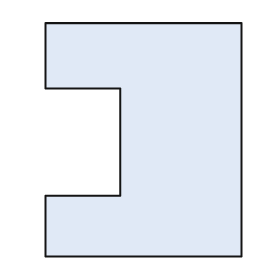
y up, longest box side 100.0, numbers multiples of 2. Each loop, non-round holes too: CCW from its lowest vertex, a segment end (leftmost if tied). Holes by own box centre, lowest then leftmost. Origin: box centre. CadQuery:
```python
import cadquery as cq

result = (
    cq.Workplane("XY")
    .moveTo(-42.0, -50.0)
    .lineTo(42.0, -50.0)
    .lineTo(42.0, 50.0)
    .lineTo(-42.0, 50.0)
    .lineTo(-42.0, 22.0)
    .lineTo(-10.0, 22.0)
    .lineTo(-10.0, -24.0)
    .lineTo(-42.0, -24.0)
    .close()
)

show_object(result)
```